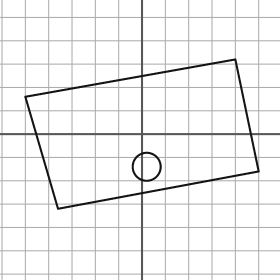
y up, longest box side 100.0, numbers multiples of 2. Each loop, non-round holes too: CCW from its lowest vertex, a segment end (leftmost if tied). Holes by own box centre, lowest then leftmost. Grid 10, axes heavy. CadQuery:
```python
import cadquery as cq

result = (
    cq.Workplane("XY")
    .moveTo(-36.0, -32.0)
    .lineTo(50.0, -16.0)
    .lineTo(40.0, 32.0)
    .lineTo(-50.0, 16.0)
    .close()
    .moveTo(2.0, -14.0)
    .circle(6.0)
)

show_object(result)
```